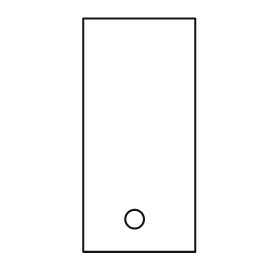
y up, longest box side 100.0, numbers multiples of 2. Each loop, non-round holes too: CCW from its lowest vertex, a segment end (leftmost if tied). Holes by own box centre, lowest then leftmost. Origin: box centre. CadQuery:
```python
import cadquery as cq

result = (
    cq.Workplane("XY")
    .moveTo(-24.0, -50.0)
    .lineTo(24.0, -50.0)
    .lineTo(24.0, 50.0)
    .lineTo(-24.0, 50.0)
    .close()
    .moveTo(-2.0, -36.0)
    .circle(4.0)
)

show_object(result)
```